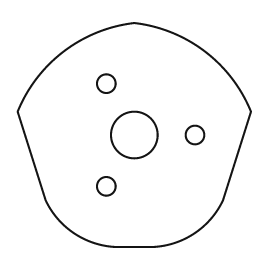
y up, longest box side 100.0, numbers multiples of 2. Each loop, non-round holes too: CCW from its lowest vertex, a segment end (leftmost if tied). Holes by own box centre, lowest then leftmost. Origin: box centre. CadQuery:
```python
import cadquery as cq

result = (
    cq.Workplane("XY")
    .moveTo(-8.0, -48.0)
    .lineTo(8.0, -48.0)
    .threePointArc((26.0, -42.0), (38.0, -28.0))
    .lineTo(50.0, 10.0)
    .threePointArc((30.0, 36.0), (0.0, 48.0))
    .threePointArc((-30.0, 36.0), (-50.0, 10.0))
    .lineTo(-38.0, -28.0)
    .threePointArc((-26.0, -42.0), (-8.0, -48.0))
    .close()
    .moveTo(-12.0, -22.0)
    .circle(4.0)
    .moveTo(0.0, 0.0)
    .circle(10.0)
    .moveTo(26.0, 0.0)
    .circle(4.0)
    .moveTo(-12.0, 22.0)
    .circle(4.0)
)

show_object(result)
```